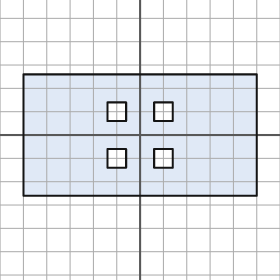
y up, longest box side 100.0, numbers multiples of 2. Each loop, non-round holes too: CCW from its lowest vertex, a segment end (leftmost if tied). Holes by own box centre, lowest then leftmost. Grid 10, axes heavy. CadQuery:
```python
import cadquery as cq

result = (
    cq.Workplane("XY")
    .moveTo(-50.0, -26.0)
    .lineTo(50.0, -26.0)
    .lineTo(50.0, 26.0)
    .lineTo(-50.0, 26.0)
    .close()
    .moveTo(-14.0, -14.0)
    .lineTo(-6.0, -14.0)
    .lineTo(-6.0, -6.0)
    .lineTo(-14.0, -6.0)
    .close()
    .moveTo(6.0, -14.0)
    .lineTo(14.0, -14.0)
    .lineTo(14.0, -6.0)
    .lineTo(6.0, -6.0)
    .close()
    .moveTo(-14.0, 6.0)
    .lineTo(-6.0, 6.0)
    .lineTo(-6.0, 14.0)
    .lineTo(-14.0, 14.0)
    .close()
    .moveTo(6.0, 6.0)
    .lineTo(14.0, 6.0)
    .lineTo(14.0, 14.0)
    .lineTo(6.0, 14.0)
    .close()
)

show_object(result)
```